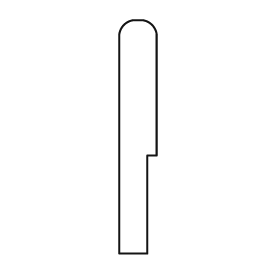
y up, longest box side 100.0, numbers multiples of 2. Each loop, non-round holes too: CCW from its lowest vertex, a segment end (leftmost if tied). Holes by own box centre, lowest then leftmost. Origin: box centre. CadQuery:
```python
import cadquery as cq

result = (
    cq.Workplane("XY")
    .moveTo(-8.0, -50.0)
    .lineTo(4.0, -50.0)
    .lineTo(4.0, -8.0)
    .lineTo(8.0, -8.0)
    .lineTo(8.0, 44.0)
    .threePointArc((6.0, 48.0), (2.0, 50.0))
    .lineTo(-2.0, 50.0)
    .threePointArc((-6.0, 48.0), (-8.0, 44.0))
    .close()
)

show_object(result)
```